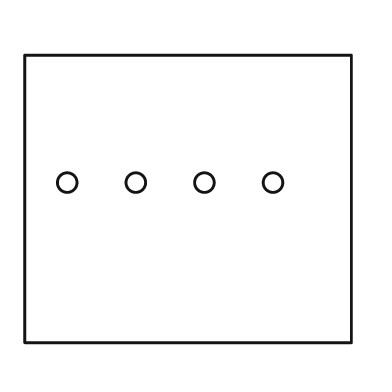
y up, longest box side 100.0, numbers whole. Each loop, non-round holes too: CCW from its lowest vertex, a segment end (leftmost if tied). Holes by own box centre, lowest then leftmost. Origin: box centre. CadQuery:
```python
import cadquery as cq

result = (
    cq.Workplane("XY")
    .moveTo(-50.0, -44.0)
    .lineTo(50.0, -44.0)
    .lineTo(50.0, 44.0)
    .lineTo(-50.0, 44.0)
    .close()
    .moveTo(-37.0, 5.0)
    .circle(3.0)
    .moveTo(-16.0, 5.0)
    .circle(3.0)
    .moveTo(5.0, 5.0)
    .circle(3.0)
    .moveTo(26.0, 5.0)
    .circle(3.0)
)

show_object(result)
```